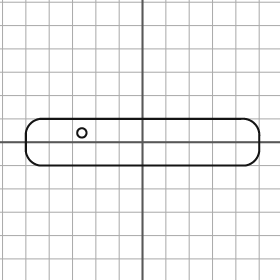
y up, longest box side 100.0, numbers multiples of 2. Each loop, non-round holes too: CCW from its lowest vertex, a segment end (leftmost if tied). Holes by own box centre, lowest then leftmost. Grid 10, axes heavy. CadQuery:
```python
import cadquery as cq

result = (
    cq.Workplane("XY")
    .moveTo(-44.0, -10.0)
    .lineTo(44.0, -10.0)
    .threePointArc((48.0, -8.0), (50.0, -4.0))
    .lineTo(50.0, 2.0)
    .threePointArc((48.0, 8.0), (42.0, 10.0))
    .lineTo(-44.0, 10.0)
    .threePointArc((-48.0, 8.0), (-50.0, 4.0))
    .lineTo(-50.0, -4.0)
    .threePointArc((-48.0, -8.0), (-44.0, -10.0))
    .close()
    .moveTo(-26.0, 4.0)
    .circle(2.0)
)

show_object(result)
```